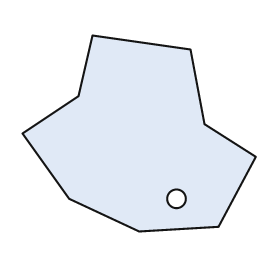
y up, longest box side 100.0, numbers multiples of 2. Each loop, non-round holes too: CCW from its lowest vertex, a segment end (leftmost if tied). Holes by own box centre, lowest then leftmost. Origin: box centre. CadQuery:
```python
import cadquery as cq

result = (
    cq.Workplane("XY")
    .moveTo(0.0, -42.0)
    .lineTo(34.0, -40.0)
    .lineTo(50.0, -10.0)
    .lineTo(28.0, 4.0)
    .lineTo(22.0, 36.0)
    .lineTo(-20.0, 42.0)
    .lineTo(-26.0, 16.0)
    .lineTo(-50.0, 0.0)
    .lineTo(-30.0, -28.0)
    .close()
    .moveTo(16.0, -28.0)
    .circle(4.0)
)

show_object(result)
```